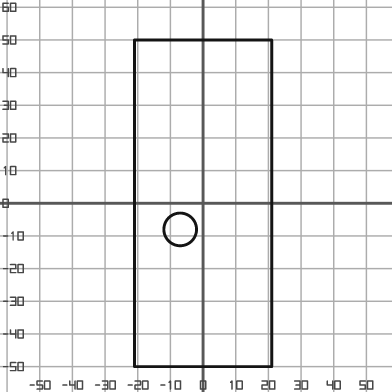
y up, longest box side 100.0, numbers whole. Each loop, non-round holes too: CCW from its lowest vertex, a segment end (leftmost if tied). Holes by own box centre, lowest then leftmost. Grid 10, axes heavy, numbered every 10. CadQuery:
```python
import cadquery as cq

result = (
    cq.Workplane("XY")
    .moveTo(-21.0, -50.0)
    .lineTo(21.0, -50.0)
    .lineTo(21.0, 50.0)
    .lineTo(-21.0, 50.0)
    .close()
    .moveTo(-7.0, -8.0)
    .circle(5.0)
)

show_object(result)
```